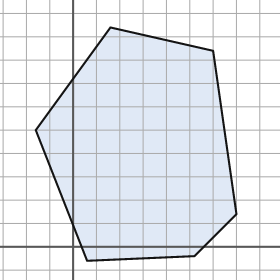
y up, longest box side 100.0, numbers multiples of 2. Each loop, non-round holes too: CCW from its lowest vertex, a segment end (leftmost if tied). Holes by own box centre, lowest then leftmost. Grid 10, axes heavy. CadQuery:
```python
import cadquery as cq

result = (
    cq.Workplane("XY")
    .moveTo(6.0, -6.0)
    .lineTo(52.0, -4.0)
    .lineTo(70.0, 14.0)
    .lineTo(60.0, 84.0)
    .lineTo(16.0, 94.0)
    .lineTo(-16.0, 50.0)
    .close()
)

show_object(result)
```